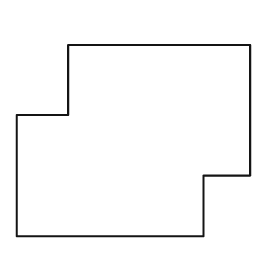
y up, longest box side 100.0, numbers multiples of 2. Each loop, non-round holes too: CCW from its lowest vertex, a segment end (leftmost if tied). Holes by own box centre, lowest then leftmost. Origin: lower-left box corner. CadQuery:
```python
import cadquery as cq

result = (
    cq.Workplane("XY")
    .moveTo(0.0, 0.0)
    .lineTo(80.0, 0.0)
    .lineTo(80.0, 26.0)
    .lineTo(100.0, 26.0)
    .lineTo(100.0, 82.0)
    .lineTo(22.0, 82.0)
    .lineTo(22.0, 52.0)
    .lineTo(0.0, 52.0)
    .close()
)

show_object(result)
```